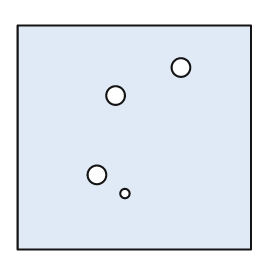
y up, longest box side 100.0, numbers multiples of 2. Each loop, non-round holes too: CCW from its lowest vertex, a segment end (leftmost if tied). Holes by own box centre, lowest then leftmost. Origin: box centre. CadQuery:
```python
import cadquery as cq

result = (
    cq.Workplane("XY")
    .moveTo(-50.0, -48.0)
    .lineTo(50.0, -48.0)
    .lineTo(50.0, 48.0)
    .lineTo(-50.0, 48.0)
    .close()
    .moveTo(-4.0, -24.0)
    .circle(2.0)
    .moveTo(-16.0, -16.0)
    .circle(4.0)
    .moveTo(-8.0, 18.0)
    .circle(4.0)
    .moveTo(20.0, 30.0)
    .circle(4.0)
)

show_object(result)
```